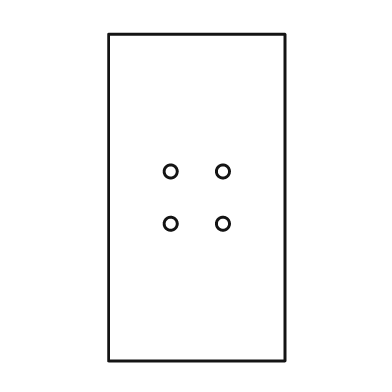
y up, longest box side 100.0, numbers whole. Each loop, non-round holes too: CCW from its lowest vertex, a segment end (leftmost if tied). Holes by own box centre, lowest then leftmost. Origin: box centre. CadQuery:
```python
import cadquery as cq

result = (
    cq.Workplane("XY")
    .moveTo(-27.0, -50.0)
    .lineTo(27.0, -50.0)
    .lineTo(27.0, 50.0)
    .lineTo(-27.0, 50.0)
    .close()
    .moveTo(-8.0, -8.0)
    .circle(2.0)
    .moveTo(8.0, -8.0)
    .circle(2.0)
    .moveTo(-8.0, 8.0)
    .circle(2.0)
    .moveTo(8.0, 8.0)
    .circle(2.0)
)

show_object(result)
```